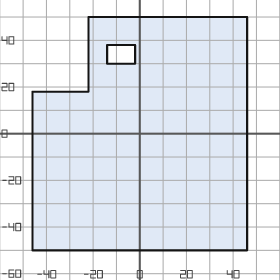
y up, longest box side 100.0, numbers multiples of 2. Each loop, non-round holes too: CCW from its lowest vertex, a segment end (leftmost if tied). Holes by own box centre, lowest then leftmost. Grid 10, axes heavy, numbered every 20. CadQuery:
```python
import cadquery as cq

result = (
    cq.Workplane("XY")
    .moveTo(-46.0, -50.0)
    .lineTo(46.0, -50.0)
    .lineTo(46.0, 50.0)
    .lineTo(-22.0, 50.0)
    .lineTo(-22.0, 18.0)
    .lineTo(-46.0, 18.0)
    .close()
    .moveTo(-14.0, 30.0)
    .lineTo(-2.0, 30.0)
    .lineTo(-2.0, 38.0)
    .lineTo(-14.0, 38.0)
    .close()
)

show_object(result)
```